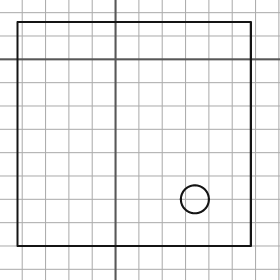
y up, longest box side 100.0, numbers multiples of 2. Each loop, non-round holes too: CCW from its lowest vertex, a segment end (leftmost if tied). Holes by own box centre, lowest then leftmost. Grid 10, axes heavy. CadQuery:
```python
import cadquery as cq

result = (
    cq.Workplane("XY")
    .moveTo(-42.0, -80.0)
    .lineTo(58.0, -80.0)
    .lineTo(58.0, 16.0)
    .lineTo(-42.0, 16.0)
    .close()
    .moveTo(34.0, -60.0)
    .circle(6.0)
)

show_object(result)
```